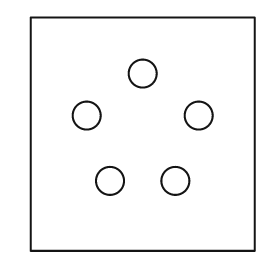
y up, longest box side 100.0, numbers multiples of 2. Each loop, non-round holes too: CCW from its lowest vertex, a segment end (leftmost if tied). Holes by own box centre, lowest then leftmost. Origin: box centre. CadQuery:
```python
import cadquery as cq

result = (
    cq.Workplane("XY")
    .moveTo(-48.0, -50.0)
    .lineTo(48.0, -50.0)
    .lineTo(48.0, 50.0)
    .lineTo(-48.0, 50.0)
    .close()
    .moveTo(-14.0, -20.0)
    .circle(6.0)
    .moveTo(14.0, -20.0)
    .circle(6.0)
    .moveTo(-24.0, 8.0)
    .circle(6.0)
    .moveTo(24.0, 8.0)
    .circle(6.0)
    .moveTo(0.0, 26.0)
    .circle(6.0)
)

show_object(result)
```